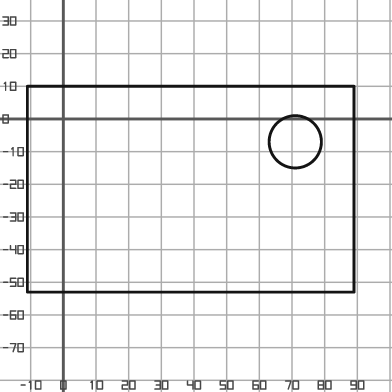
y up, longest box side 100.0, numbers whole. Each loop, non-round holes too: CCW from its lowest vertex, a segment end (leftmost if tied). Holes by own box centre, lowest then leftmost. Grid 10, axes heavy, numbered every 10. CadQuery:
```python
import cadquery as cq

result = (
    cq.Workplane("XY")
    .moveTo(-11.0, -53.0)
    .lineTo(89.0, -53.0)
    .lineTo(89.0, 10.0)
    .lineTo(-11.0, 10.0)
    .close()
    .moveTo(71.0, -7.0)
    .circle(8.0)
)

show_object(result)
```